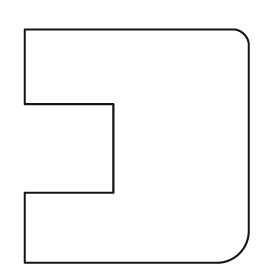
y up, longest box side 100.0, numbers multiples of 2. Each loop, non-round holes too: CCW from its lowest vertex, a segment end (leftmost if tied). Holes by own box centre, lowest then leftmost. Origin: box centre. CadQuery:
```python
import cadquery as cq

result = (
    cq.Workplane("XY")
    .moveTo(-48.0, -50.0)
    .lineTo(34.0, -50.0)
    .threePointArc((44.0, -46.0), (48.0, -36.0))
    .lineTo(48.0, 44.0)
    .threePointArc((46.0, 48.0), (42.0, 50.0))
    .lineTo(-48.0, 50.0)
    .lineTo(-48.0, 18.0)
    .lineTo(-10.0, 18.0)
    .lineTo(-10.0, -20.0)
    .lineTo(-48.0, -20.0)
    .close()
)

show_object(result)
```